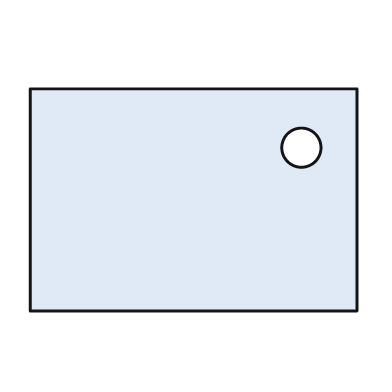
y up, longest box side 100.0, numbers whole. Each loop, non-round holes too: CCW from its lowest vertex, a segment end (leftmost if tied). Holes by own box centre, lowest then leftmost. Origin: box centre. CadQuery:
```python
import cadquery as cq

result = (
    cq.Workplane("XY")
    .moveTo(-50.0, -34.0)
    .lineTo(50.0, -34.0)
    .lineTo(50.0, 34.0)
    .lineTo(-50.0, 34.0)
    .close()
    .moveTo(33.0, 16.0)
    .circle(6.0)
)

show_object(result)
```